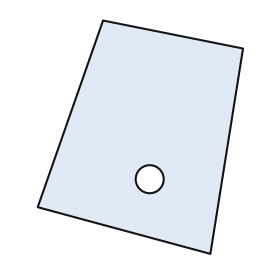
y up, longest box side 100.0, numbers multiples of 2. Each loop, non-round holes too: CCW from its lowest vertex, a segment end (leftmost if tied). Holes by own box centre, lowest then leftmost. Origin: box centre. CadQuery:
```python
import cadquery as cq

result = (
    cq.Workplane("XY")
    .moveTo(30.0, -50.0)
    .lineTo(44.0, 38.0)
    .lineTo(-16.0, 50.0)
    .lineTo(-44.0, -30.0)
    .close()
    .moveTo(4.0, -18.0)
    .circle(6.0)
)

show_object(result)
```